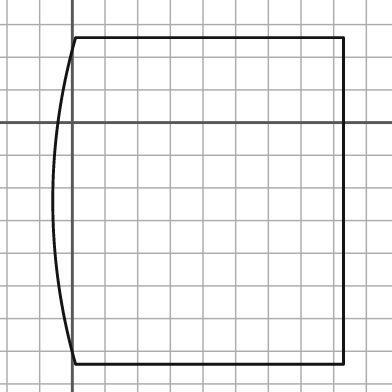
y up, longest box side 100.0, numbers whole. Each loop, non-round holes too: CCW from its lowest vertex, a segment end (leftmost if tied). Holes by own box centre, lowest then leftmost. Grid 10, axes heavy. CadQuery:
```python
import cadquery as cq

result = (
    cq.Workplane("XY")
    .moveTo(1.0, -74.0)
    .lineTo(83.0, -74.0)
    .lineTo(83.0, 26.0)
    .lineTo(1.0, 26.0)
    .threePointArc((-6.0, -24.0), (1.0, -74.0))
    .close()
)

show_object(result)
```